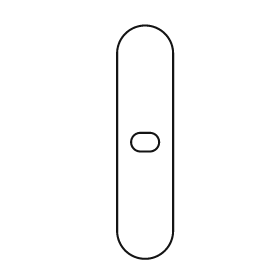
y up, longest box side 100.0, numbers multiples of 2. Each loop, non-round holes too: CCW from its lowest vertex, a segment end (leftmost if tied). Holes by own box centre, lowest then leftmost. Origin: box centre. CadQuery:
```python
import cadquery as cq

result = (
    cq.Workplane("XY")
    .moveTo(-12.0, -38.0)
    .threePointArc((0.0, -50.0), (12.0, -38.0))
    .lineTo(12.0, 38.0)
    .threePointArc((0.0, 50.0), (-12.0, 38.0))
    .close()
    .moveTo(-2.0, -4.0)
    .lineTo(2.0, -4.0)
    .threePointArc((6.0, 0.0), (2.0, 4.0))
    .lineTo(-2.0, 4.0)
    .threePointArc((-6.0, 0.0), (-2.0, -4.0))
    .close()
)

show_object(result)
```